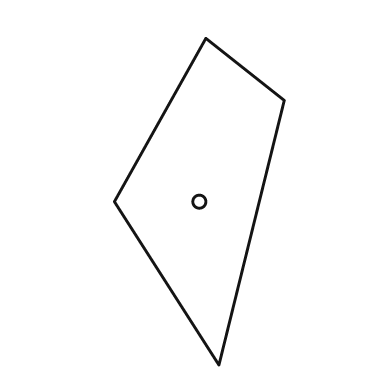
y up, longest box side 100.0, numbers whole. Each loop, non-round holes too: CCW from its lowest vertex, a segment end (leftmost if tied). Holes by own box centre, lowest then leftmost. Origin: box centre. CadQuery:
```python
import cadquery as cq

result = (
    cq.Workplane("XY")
    .moveTo(6.0, -50.0)
    .lineTo(26.0, 31.0)
    .lineTo(2.0, 50.0)
    .lineTo(-26.0, 0.0)
    .close()
    .moveTo(0.0, 0.0)
    .circle(2.0)
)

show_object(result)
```